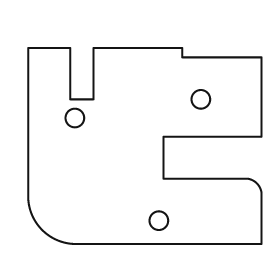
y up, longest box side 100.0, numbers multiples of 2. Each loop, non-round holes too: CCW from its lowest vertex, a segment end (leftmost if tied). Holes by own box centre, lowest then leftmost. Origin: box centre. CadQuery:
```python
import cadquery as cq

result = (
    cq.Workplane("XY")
    .moveTo(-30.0, -42.0)
    .lineTo(50.0, -42.0)
    .lineTo(50.0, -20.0)
    .threePointArc((48.0, -16.0), (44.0, -14.0))
    .lineTo(8.0, -14.0)
    .lineTo(8.0, 4.0)
    .lineTo(50.0, 4.0)
    .lineTo(50.0, 38.0)
    .lineTo(16.0, 38.0)
    .lineTo(16.0, 42.0)
    .lineTo(-22.0, 42.0)
    .lineTo(-22.0, 20.0)
    .lineTo(-32.0, 20.0)
    .lineTo(-32.0, 42.0)
    .lineTo(-50.0, 42.0)
    .lineTo(-50.0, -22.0)
    .threePointArc((-44.0, -36.0), (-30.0, -42.0))
    .close()
    .moveTo(6.0, -32.0)
    .circle(4.0)
    .moveTo(-30.0, 12.0)
    .circle(4.0)
    .moveTo(24.0, 20.0)
    .circle(4.0)
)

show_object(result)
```